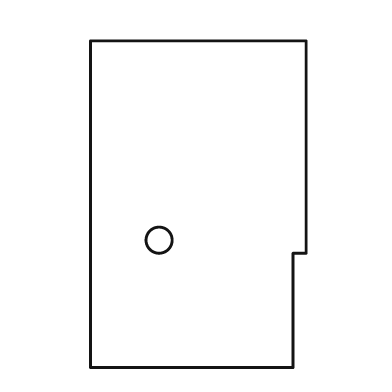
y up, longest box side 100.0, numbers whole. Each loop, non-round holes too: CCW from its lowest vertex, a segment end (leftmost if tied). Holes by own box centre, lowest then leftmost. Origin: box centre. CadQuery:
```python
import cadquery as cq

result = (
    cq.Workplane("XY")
    .moveTo(-33.0, -50.0)
    .lineTo(29.0, -50.0)
    .lineTo(29.0, -15.0)
    .lineTo(33.0, -15.0)
    .lineTo(33.0, 50.0)
    .lineTo(-33.0, 50.0)
    .close()
    .moveTo(-12.0, -11.0)
    .circle(4.0)
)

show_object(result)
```